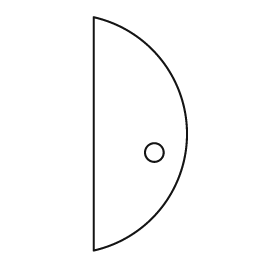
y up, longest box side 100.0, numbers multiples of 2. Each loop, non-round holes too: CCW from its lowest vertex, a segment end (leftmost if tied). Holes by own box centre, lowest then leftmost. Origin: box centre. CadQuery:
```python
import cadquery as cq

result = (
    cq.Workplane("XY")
    .moveTo(-20.0, -50.0)
    .threePointArc((20.0, 0.0), (-20.0, 50.0))
    .close()
    .moveTo(6.0, -8.0)
    .circle(4.0)
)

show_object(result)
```